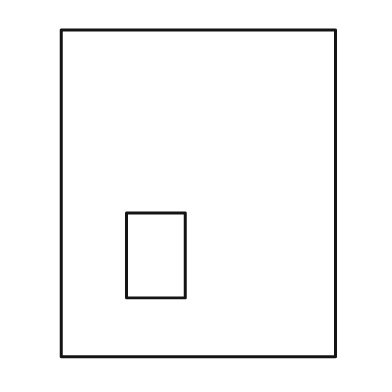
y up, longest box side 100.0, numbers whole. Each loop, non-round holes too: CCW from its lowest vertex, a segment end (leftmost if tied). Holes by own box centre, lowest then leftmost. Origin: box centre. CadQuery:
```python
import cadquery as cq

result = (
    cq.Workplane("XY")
    .moveTo(-42.0, -50.0)
    .lineTo(42.0, -50.0)
    .lineTo(42.0, 50.0)
    .lineTo(-42.0, 50.0)
    .close()
    .moveTo(-22.0, -32.0)
    .lineTo(-4.0, -32.0)
    .lineTo(-4.0, -6.0)
    .lineTo(-22.0, -6.0)
    .close()
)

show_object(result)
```